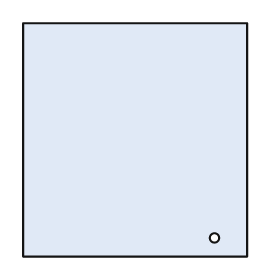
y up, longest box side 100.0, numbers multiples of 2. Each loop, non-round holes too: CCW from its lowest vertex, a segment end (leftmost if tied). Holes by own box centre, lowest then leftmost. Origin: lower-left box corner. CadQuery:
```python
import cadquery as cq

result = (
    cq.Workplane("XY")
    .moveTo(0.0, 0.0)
    .lineTo(96.0, 0.0)
    .lineTo(96.0, 100.0)
    .lineTo(0.0, 100.0)
    .close()
    .moveTo(82.0, 8.0)
    .circle(2.0)
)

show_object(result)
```